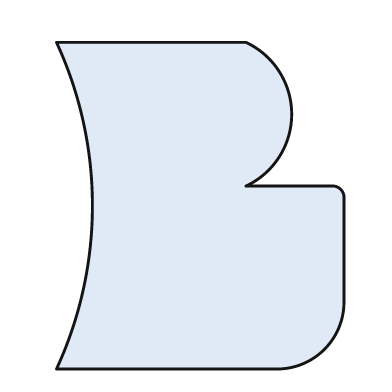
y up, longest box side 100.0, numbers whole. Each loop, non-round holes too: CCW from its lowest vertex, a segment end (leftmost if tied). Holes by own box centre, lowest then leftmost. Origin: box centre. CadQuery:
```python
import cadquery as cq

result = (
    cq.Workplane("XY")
    .moveTo(-44.0, -50.0)
    .lineTo(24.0, -50.0)
    .threePointArc((38.0, -44.0), (44.0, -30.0))
    .lineTo(44.0, 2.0)
    .threePointArc((43.0, 5.0), (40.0, 6.0))
    .lineTo(14.0, 6.0)
    .threePointArc((28.0, 28.0), (14.0, 50.0))
    .lineTo(-44.0, 50.0)
    .threePointArc((-33.0, 0.0), (-44.0, -50.0))
    .close()
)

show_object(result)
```